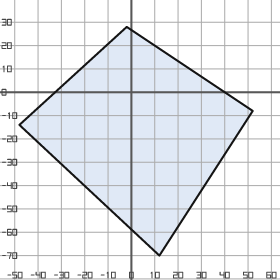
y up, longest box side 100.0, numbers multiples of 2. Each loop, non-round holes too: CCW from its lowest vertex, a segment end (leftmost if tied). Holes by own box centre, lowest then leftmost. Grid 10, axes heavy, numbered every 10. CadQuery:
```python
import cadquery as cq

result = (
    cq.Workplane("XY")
    .moveTo(12.0, -70.0)
    .lineTo(52.0, -8.0)
    .lineTo(-2.0, 28.0)
    .lineTo(-48.0, -14.0)
    .close()
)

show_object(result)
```